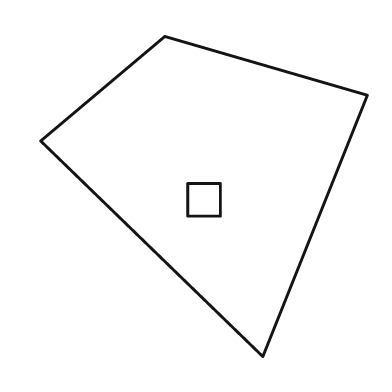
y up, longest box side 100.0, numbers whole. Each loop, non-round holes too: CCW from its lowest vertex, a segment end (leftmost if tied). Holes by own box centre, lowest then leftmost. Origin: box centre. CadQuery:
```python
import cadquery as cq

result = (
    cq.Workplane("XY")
    .moveTo(18.0, -49.0)
    .lineTo(50.0, 31.0)
    .lineTo(-12.0, 49.0)
    .lineTo(-50.0, 17.0)
    .close()
    .moveTo(-5.0, -6.0)
    .lineTo(5.0, -6.0)
    .lineTo(5.0, 4.0)
    .lineTo(-5.0, 4.0)
    .close()
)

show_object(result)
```